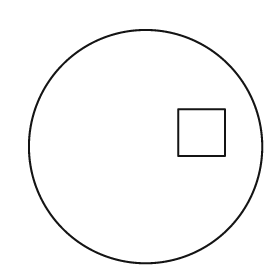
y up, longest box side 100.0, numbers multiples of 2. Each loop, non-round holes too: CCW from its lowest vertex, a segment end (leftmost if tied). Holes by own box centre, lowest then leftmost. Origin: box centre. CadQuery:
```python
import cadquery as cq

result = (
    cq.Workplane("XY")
    .moveTo(0.0, 0.0)
    .circle(50.0)
    .moveTo(14.0, -4.0)
    .lineTo(34.0, -4.0)
    .lineTo(34.0, 16.0)
    .lineTo(14.0, 16.0)
    .close()
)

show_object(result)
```